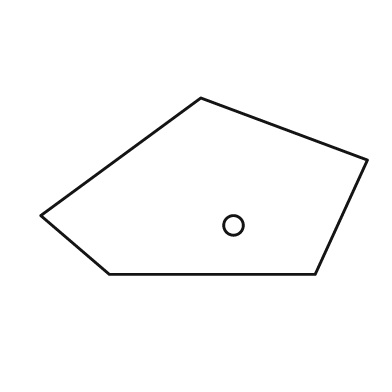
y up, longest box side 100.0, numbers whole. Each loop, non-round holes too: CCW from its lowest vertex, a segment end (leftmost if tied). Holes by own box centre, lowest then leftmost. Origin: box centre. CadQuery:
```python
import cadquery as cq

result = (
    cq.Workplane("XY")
    .moveTo(-29.0, -27.0)
    .lineTo(34.0, -27.0)
    .lineTo(50.0, 8.0)
    .lineTo(-1.0, 27.0)
    .lineTo(-50.0, -9.0)
    .close()
    .moveTo(9.0, -12.0)
    .circle(3.0)
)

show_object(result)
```